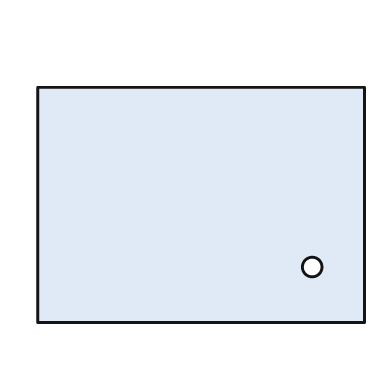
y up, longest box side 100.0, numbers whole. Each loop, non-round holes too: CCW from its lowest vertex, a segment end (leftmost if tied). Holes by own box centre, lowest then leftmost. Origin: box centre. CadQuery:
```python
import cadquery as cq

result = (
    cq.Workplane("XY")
    .moveTo(-50.0, -36.0)
    .lineTo(50.0, -36.0)
    .lineTo(50.0, 36.0)
    .lineTo(-50.0, 36.0)
    .close()
    .moveTo(34.0, -19.0)
    .circle(3.0)
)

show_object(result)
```